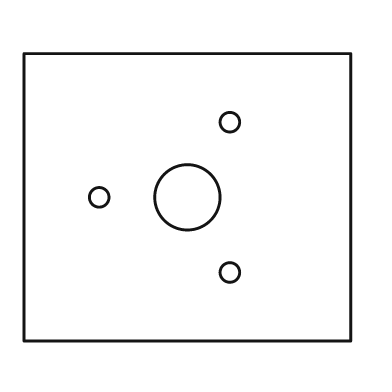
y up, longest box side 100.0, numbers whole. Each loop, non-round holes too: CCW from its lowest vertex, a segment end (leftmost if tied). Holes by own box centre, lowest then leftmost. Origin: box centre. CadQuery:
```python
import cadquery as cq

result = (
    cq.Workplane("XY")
    .moveTo(-50.0, -44.0)
    .lineTo(50.0, -44.0)
    .lineTo(50.0, 44.0)
    .lineTo(-50.0, 44.0)
    .close()
    .moveTo(13.0, -23.0)
    .circle(3.0)
    .moveTo(-27.0, 0.0)
    .circle(3.0)
    .moveTo(0.0, 0.0)
    .circle(10.0)
    .moveTo(13.0, 23.0)
    .circle(3.0)
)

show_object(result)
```